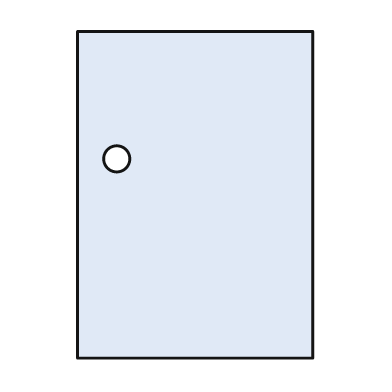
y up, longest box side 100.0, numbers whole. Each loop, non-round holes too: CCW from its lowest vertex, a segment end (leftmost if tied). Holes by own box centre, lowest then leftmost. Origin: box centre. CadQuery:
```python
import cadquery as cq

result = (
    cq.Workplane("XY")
    .moveTo(-36.0, -50.0)
    .lineTo(36.0, -50.0)
    .lineTo(36.0, 50.0)
    .lineTo(-36.0, 50.0)
    .close()
    .moveTo(-24.0, 11.0)
    .circle(4.0)
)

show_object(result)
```